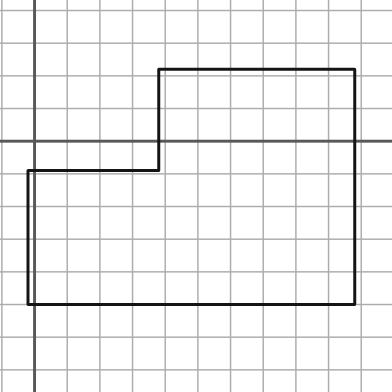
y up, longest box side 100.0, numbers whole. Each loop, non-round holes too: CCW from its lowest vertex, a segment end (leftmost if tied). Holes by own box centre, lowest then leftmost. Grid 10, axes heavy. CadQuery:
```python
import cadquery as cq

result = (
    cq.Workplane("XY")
    .moveTo(-2.0, -50.0)
    .lineTo(98.0, -50.0)
    .lineTo(98.0, 22.0)
    .lineTo(38.0, 22.0)
    .lineTo(38.0, -9.0)
    .lineTo(-2.0, -9.0)
    .close()
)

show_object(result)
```